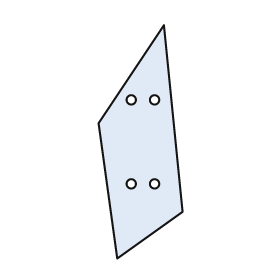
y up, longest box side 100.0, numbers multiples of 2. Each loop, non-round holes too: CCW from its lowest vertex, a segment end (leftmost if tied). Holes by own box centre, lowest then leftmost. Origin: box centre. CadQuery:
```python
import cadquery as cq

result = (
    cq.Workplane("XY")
    .moveTo(-10.0, -50.0)
    .lineTo(18.0, -30.0)
    .lineTo(10.0, 50.0)
    .lineTo(-18.0, 8.0)
    .close()
    .moveTo(-4.0, -18.0)
    .circle(2.0)
    .moveTo(6.0, -18.0)
    .circle(2.0)
    .moveTo(-4.0, 18.0)
    .circle(2.0)
    .moveTo(6.0, 18.0)
    .circle(2.0)
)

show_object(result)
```